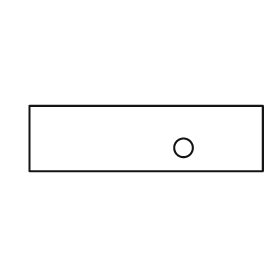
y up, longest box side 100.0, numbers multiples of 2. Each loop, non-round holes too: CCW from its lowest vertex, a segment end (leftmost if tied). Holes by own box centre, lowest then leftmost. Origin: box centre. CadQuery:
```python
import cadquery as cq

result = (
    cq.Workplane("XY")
    .moveTo(-50.0, -14.0)
    .lineTo(50.0, -14.0)
    .lineTo(50.0, 14.0)
    .lineTo(-50.0, 14.0)
    .close()
    .moveTo(16.0, -4.0)
    .circle(4.0)
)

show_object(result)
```